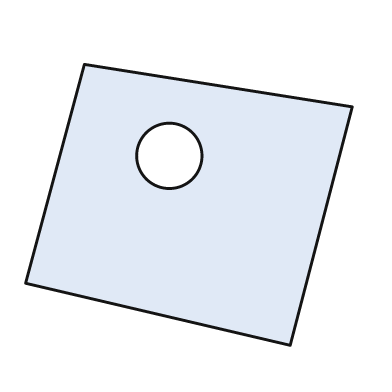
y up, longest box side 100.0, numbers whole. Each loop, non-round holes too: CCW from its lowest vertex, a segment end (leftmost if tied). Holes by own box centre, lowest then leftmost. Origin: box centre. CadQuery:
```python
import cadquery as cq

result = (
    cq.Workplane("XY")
    .moveTo(31.0, -43.0)
    .lineTo(50.0, 30.0)
    .lineTo(-32.0, 43.0)
    .lineTo(-50.0, -24.0)
    .close()
    .moveTo(-6.0, 15.0)
    .circle(10.0)
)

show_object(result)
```